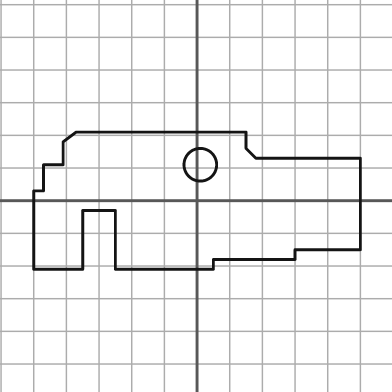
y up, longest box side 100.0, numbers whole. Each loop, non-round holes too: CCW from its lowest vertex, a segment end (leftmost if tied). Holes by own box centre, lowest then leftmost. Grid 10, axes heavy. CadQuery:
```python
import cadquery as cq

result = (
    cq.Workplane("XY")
    .moveTo(-50.0, -21.0)
    .lineTo(-35.0, -21.0)
    .lineTo(-35.0, -3.0)
    .lineTo(-25.0, -3.0)
    .lineTo(-25.0, -21.0)
    .lineTo(5.0, -21.0)
    .lineTo(5.0, -18.0)
    .lineTo(30.0, -18.0)
    .lineTo(30.0, -15.0)
    .lineTo(50.0, -15.0)
    .lineTo(50.0, 13.0)
    .lineTo(18.0, 13.0)
    .lineTo(15.0, 16.0)
    .lineTo(15.0, 21.0)
    .lineTo(-37.0, 21.0)
    .lineTo(-41.0, 18.0)
    .lineTo(-41.0, 11.0)
    .lineTo(-47.0, 11.0)
    .lineTo(-47.0, 3.0)
    .lineTo(-50.0, 3.0)
    .close()
    .moveTo(1.0, 11.0)
    .circle(5.0)
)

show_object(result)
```